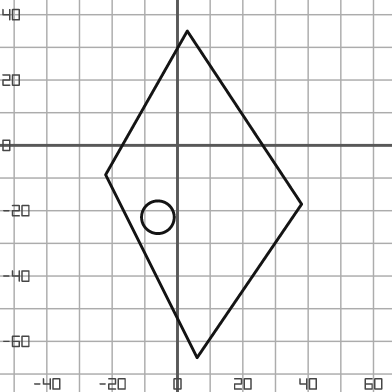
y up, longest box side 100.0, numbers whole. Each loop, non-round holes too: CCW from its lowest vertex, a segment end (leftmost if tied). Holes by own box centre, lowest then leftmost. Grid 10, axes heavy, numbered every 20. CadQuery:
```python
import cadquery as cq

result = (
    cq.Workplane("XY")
    .moveTo(6.0, -65.0)
    .lineTo(38.0, -18.0)
    .lineTo(3.0, 35.0)
    .lineTo(-22.0, -9.0)
    .close()
    .moveTo(-6.0, -22.0)
    .circle(5.0)
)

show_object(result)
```